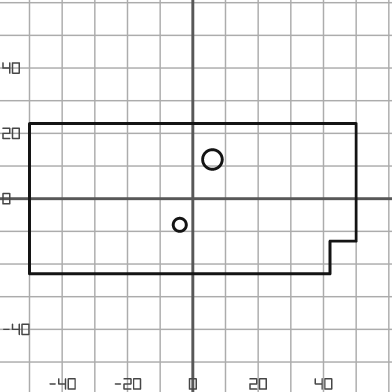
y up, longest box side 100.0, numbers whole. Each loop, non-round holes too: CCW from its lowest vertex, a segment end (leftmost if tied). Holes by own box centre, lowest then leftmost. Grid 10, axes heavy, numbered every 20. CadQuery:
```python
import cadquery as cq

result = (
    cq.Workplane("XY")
    .moveTo(-50.0, -23.0)
    .lineTo(42.0, -23.0)
    .lineTo(42.0, -13.0)
    .lineTo(50.0, -13.0)
    .lineTo(50.0, 23.0)
    .lineTo(-50.0, 23.0)
    .close()
    .moveTo(-4.0, -8.0)
    .circle(2.0)
    .moveTo(6.0, 12.0)
    .circle(3.0)
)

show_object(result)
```